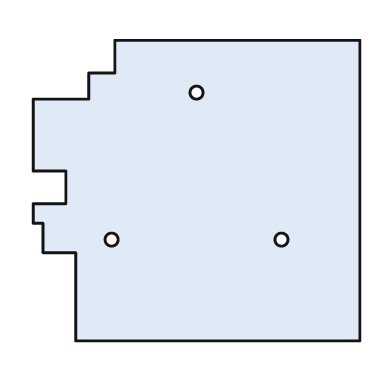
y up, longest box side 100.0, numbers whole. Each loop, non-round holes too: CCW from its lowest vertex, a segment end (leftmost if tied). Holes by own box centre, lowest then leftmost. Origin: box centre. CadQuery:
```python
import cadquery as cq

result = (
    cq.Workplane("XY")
    .moveTo(-37.0, -46.0)
    .lineTo(50.0, -46.0)
    .lineTo(50.0, 46.0)
    .lineTo(-25.0, 46.0)
    .lineTo(-25.0, 36.0)
    .lineTo(-33.0, 36.0)
    .lineTo(-33.0, 28.0)
    .lineTo(-50.0, 28.0)
    .lineTo(-50.0, 6.0)
    .lineTo(-40.0, 6.0)
    .lineTo(-40.0, -4.0)
    .lineTo(-50.0, -4.0)
    .lineTo(-50.0, -10.0)
    .lineTo(-47.0, -10.0)
    .lineTo(-47.0, -19.0)
    .lineTo(-37.0, -19.0)
    .close()
    .moveTo(-26.0, -15.0)
    .circle(2.0)
    .moveTo(26.0, -15.0)
    .circle(2.0)
    .moveTo(0.0, 30.0)
    .circle(2.0)
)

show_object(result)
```